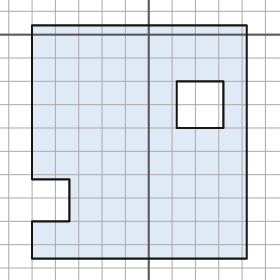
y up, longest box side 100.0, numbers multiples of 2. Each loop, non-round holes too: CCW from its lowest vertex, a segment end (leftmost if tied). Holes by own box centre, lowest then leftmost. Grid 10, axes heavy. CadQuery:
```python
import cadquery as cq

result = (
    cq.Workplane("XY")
    .moveTo(-50.0, -96.0)
    .lineTo(42.0, -96.0)
    .lineTo(42.0, 4.0)
    .lineTo(-50.0, 4.0)
    .lineTo(-50.0, -62.0)
    .lineTo(-34.0, -62.0)
    .lineTo(-34.0, -80.0)
    .lineTo(-50.0, -80.0)
    .close()
    .moveTo(12.0, -40.0)
    .lineTo(32.0, -40.0)
    .lineTo(32.0, -20.0)
    .lineTo(12.0, -20.0)
    .close()
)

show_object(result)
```